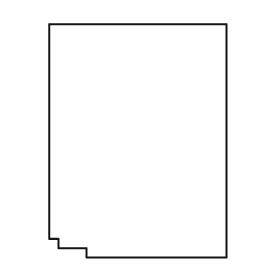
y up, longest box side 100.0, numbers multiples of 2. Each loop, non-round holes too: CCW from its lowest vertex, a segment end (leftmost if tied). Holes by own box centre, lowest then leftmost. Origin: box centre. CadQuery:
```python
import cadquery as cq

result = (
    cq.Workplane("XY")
    .moveTo(-22.0, -50.0)
    .lineTo(38.0, -50.0)
    .lineTo(38.0, 50.0)
    .lineTo(-38.0, 50.0)
    .lineTo(-38.0, -42.0)
    .lineTo(-34.0, -42.0)
    .lineTo(-34.0, -46.0)
    .lineTo(-22.0, -46.0)
    .close()
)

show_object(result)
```